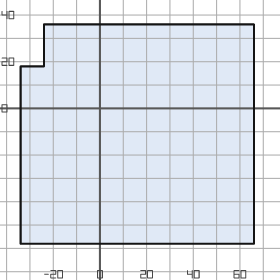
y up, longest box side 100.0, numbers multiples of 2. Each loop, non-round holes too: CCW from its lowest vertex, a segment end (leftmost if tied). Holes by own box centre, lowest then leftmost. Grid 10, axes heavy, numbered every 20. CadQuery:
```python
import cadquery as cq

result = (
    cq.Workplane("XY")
    .moveTo(-34.0, -58.0)
    .lineTo(66.0, -58.0)
    .lineTo(66.0, 36.0)
    .lineTo(-24.0, 36.0)
    .lineTo(-24.0, 18.0)
    .lineTo(-34.0, 18.0)
    .close()
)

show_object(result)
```